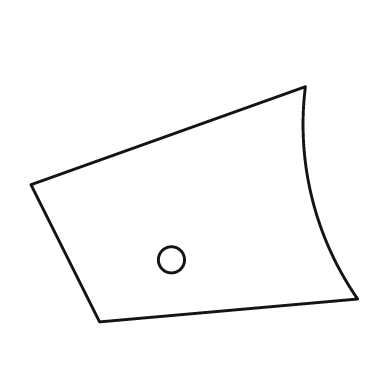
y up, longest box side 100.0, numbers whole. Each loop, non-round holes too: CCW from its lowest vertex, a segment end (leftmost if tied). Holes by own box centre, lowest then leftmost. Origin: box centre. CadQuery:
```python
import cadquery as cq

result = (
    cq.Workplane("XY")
    .moveTo(-29.0, -36.0)
    .lineTo(50.0, -29.0)
    .threePointArc((36.0, 2.0), (34.0, 36.0))
    .lineTo(-50.0, 6.0)
    .close()
    .moveTo(-7.0, -17.0)
    .circle(4.0)
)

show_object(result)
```